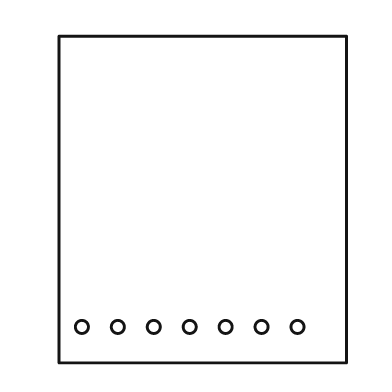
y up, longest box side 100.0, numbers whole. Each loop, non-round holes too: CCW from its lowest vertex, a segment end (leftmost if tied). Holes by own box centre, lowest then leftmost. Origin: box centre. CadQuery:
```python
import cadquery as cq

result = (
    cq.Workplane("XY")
    .moveTo(-44.0, -50.0)
    .lineTo(44.0, -50.0)
    .lineTo(44.0, 50.0)
    .lineTo(-44.0, 50.0)
    .close()
    .moveTo(-37.0, -39.0)
    .circle(2.0)
    .moveTo(-26.0, -39.0)
    .circle(2.0)
    .moveTo(-15.0, -39.0)
    .circle(2.0)
    .moveTo(-4.0, -39.0)
    .circle(2.0)
    .moveTo(7.0, -39.0)
    .circle(2.0)
    .moveTo(18.0, -39.0)
    .circle(2.0)
    .moveTo(29.0, -39.0)
    .circle(2.0)
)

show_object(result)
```